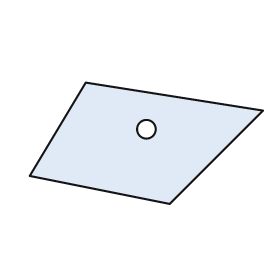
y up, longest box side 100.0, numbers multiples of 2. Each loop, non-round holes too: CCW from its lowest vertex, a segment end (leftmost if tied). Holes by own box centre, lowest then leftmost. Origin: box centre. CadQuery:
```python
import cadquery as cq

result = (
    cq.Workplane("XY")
    .moveTo(10.0, -26.0)
    .lineTo(50.0, 14.0)
    .lineTo(-26.0, 26.0)
    .lineTo(-50.0, -14.0)
    .close()
    .moveTo(0.0, 6.0)
    .circle(4.0)
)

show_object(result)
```